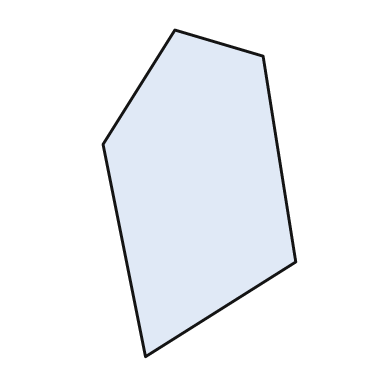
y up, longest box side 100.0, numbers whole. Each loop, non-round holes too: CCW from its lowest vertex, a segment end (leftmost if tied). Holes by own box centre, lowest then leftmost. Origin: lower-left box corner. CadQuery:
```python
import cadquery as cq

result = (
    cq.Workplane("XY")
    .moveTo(13.0, 0.0)
    .lineTo(59.0, 29.0)
    .lineTo(49.0, 92.0)
    .lineTo(22.0, 100.0)
    .lineTo(0.0, 65.0)
    .close()
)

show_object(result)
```